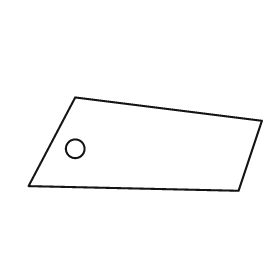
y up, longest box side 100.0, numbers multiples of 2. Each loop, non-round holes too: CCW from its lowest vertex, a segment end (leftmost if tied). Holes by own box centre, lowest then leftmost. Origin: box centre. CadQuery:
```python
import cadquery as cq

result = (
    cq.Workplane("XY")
    .moveTo(40.0, -20.0)
    .lineTo(50.0, 10.0)
    .lineTo(-30.0, 20.0)
    .lineTo(-50.0, -18.0)
    .close()
    .moveTo(-30.0, -2.0)
    .circle(4.0)
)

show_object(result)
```